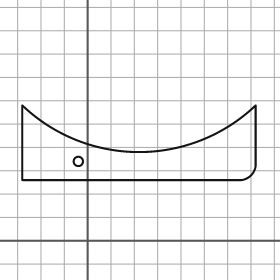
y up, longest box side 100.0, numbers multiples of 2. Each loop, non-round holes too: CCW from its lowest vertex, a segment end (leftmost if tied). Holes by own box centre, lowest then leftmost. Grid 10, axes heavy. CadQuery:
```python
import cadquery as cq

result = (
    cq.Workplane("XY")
    .moveTo(-28.0, 26.0)
    .lineTo(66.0, 26.0)
    .threePointArc((70.0, 28.0), (72.0, 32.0))
    .lineTo(72.0, 58.0)
    .threePointArc((22.0, 38.0), (-28.0, 58.0))
    .close()
    .moveTo(-4.0, 34.0)
    .circle(2.0)
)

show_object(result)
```